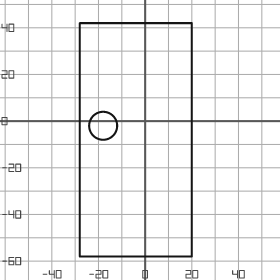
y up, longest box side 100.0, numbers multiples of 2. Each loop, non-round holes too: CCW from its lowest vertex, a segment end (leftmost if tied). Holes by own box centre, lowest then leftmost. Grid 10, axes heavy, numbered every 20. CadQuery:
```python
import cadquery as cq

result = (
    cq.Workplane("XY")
    .moveTo(-28.0, -58.0)
    .lineTo(20.0, -58.0)
    .lineTo(20.0, 42.0)
    .lineTo(-28.0, 42.0)
    .close()
    .moveTo(-18.0, -2.0)
    .circle(6.0)
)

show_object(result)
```